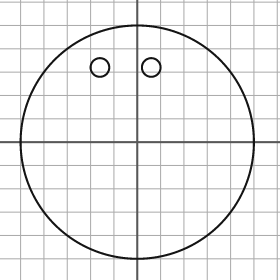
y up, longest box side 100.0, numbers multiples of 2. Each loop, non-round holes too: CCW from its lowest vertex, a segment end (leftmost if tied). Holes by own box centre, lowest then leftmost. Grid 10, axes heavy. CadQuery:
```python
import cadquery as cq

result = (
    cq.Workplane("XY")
    .moveTo(0.0, 0.0)
    .circle(50.0)
    .moveTo(-16.0, 32.0)
    .circle(4.0)
    .moveTo(6.0, 32.0)
    .circle(4.0)
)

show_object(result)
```